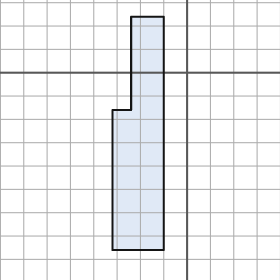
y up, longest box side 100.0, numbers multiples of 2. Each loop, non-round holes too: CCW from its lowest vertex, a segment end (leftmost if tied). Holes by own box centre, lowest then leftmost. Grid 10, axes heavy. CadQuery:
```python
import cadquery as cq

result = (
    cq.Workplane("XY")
    .moveTo(-32.0, -76.0)
    .lineTo(-10.0, -76.0)
    .lineTo(-10.0, 24.0)
    .lineTo(-24.0, 24.0)
    .lineTo(-24.0, -16.0)
    .lineTo(-32.0, -16.0)
    .close()
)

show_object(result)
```